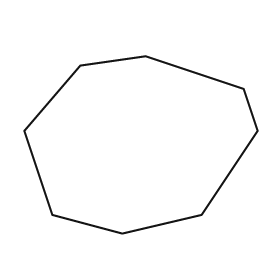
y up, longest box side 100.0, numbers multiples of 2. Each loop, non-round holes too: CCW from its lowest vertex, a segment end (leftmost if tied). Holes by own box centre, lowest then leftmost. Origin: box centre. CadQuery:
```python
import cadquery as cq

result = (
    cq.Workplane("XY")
    .moveTo(-8.0, -38.0)
    .lineTo(26.0, -30.0)
    .lineTo(50.0, 6.0)
    .lineTo(44.0, 24.0)
    .lineTo(2.0, 38.0)
    .lineTo(-26.0, 34.0)
    .lineTo(-50.0, 6.0)
    .lineTo(-38.0, -30.0)
    .close()
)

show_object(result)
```